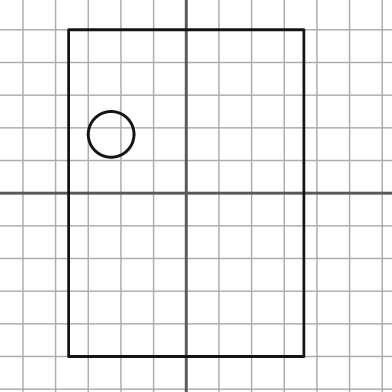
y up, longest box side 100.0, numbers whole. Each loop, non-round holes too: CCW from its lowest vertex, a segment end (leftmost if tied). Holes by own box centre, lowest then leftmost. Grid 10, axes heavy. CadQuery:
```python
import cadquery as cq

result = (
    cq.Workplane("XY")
    .moveTo(-36.0, -50.0)
    .lineTo(36.0, -50.0)
    .lineTo(36.0, 50.0)
    .lineTo(-36.0, 50.0)
    .close()
    .moveTo(-23.0, 18.0)
    .circle(7.0)
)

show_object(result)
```